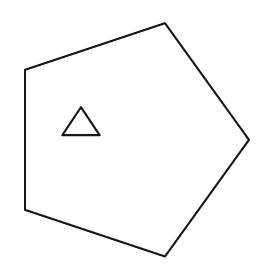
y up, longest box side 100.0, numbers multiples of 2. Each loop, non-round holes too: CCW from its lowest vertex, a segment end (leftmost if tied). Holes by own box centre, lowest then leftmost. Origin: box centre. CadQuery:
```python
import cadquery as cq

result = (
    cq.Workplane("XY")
    .moveTo(12.0, -50.0)
    .lineTo(48.0, 0.0)
    .lineTo(12.0, 50.0)
    .lineTo(-48.0, 30.0)
    .lineTo(-48.0, -30.0)
    .close()
    .moveTo(-32.0, 2.0)
    .lineTo(-16.0, 2.0)
    .lineTo(-24.0, 14.0)
    .close()
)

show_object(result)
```